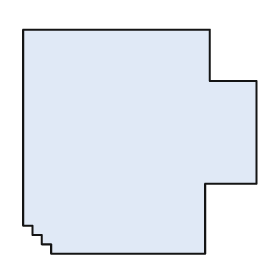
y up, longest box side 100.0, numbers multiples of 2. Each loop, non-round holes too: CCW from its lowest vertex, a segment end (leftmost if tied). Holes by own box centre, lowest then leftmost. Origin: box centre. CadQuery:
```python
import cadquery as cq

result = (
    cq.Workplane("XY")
    .moveTo(-38.0, -48.0)
    .lineTo(28.0, -48.0)
    .lineTo(28.0, -18.0)
    .lineTo(50.0, -18.0)
    .lineTo(50.0, 26.0)
    .lineTo(30.0, 26.0)
    .lineTo(30.0, 48.0)
    .lineTo(-50.0, 48.0)
    .lineTo(-50.0, -36.0)
    .lineTo(-46.0, -36.0)
    .lineTo(-46.0, -40.0)
    .lineTo(-42.0, -40.0)
    .lineTo(-42.0, -44.0)
    .lineTo(-38.0, -44.0)
    .close()
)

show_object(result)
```